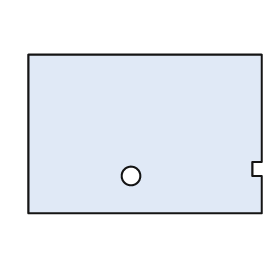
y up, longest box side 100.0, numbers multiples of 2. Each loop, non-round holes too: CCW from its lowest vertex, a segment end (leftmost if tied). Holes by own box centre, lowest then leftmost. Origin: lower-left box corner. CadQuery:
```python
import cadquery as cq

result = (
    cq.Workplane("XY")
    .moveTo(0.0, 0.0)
    .lineTo(100.0, 0.0)
    .lineTo(100.0, 16.0)
    .lineTo(96.0, 16.0)
    .lineTo(96.0, 22.0)
    .lineTo(100.0, 22.0)
    .lineTo(100.0, 68.0)
    .lineTo(0.0, 68.0)
    .close()
    .moveTo(44.0, 16.0)
    .circle(4.0)
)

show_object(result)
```